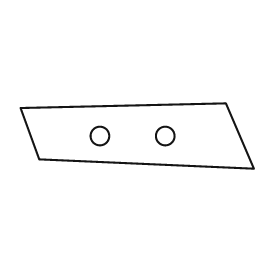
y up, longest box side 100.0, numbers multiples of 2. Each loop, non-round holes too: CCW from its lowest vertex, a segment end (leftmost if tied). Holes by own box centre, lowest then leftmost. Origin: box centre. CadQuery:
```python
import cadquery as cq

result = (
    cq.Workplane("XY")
    .moveTo(50.0, -14.0)
    .lineTo(38.0, 14.0)
    .lineTo(-50.0, 12.0)
    .lineTo(-42.0, -10.0)
    .close()
    .moveTo(-16.0, 0.0)
    .circle(4.0)
    .moveTo(12.0, 0.0)
    .circle(4.0)
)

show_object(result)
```